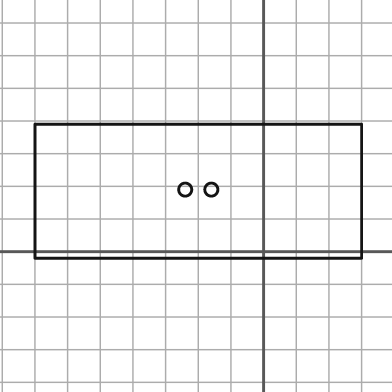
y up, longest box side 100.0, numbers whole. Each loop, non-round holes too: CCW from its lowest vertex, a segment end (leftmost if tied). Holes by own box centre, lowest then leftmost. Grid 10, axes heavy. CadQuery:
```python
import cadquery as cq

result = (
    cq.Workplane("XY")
    .moveTo(-70.0, -2.0)
    .lineTo(30.0, -2.0)
    .lineTo(30.0, 39.0)
    .lineTo(-70.0, 39.0)
    .close()
    .moveTo(-24.0, 19.0)
    .circle(2.0)
    .moveTo(-16.0, 19.0)
    .circle(2.0)
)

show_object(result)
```